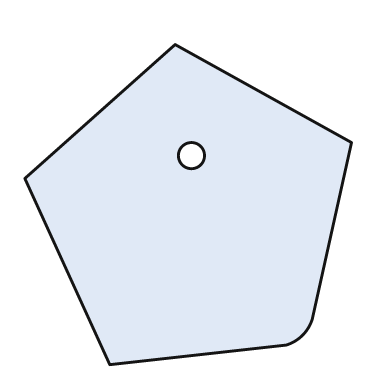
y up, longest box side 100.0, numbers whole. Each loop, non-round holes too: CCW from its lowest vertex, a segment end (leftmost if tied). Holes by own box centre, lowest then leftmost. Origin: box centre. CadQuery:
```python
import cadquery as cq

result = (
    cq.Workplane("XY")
    .moveTo(-24.0, -49.0)
    .lineTo(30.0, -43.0)
    .threePointArc((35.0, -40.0), (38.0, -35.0))
    .lineTo(50.0, 19.0)
    .lineTo(-4.0, 49.0)
    .lineTo(-50.0, 8.0)
    .close()
    .moveTo(1.0, 15.0)
    .circle(4.0)
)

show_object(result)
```